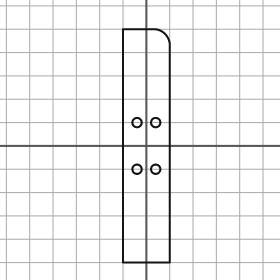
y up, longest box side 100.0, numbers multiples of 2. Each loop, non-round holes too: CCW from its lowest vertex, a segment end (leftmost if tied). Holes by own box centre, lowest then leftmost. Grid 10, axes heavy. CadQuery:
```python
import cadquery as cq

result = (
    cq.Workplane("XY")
    .moveTo(-10.0, -50.0)
    .lineTo(10.0, -50.0)
    .lineTo(10.0, 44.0)
    .threePointArc((8.0, 48.0), (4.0, 50.0))
    .lineTo(-10.0, 50.0)
    .close()
    .moveTo(-4.0, -10.0)
    .circle(2.0)
    .moveTo(4.0, -10.0)
    .circle(2.0)
    .moveTo(-4.0, 10.0)
    .circle(2.0)
    .moveTo(4.0, 10.0)
    .circle(2.0)
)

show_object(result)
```